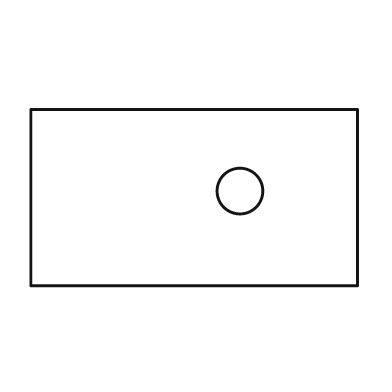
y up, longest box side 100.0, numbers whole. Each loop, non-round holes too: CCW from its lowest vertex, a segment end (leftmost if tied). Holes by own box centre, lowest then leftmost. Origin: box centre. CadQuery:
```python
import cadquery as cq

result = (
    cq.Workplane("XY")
    .moveTo(-50.0, -27.0)
    .lineTo(50.0, -27.0)
    .lineTo(50.0, 27.0)
    .lineTo(-50.0, 27.0)
    .close()
    .moveTo(14.0, 2.0)
    .circle(7.0)
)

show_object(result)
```